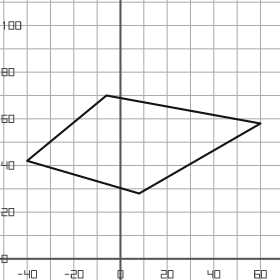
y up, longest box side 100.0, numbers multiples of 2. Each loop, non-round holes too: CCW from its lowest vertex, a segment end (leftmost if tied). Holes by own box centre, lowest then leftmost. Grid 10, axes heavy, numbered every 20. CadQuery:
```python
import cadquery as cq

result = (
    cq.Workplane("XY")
    .moveTo(8.0, 28.0)
    .lineTo(60.0, 58.0)
    .lineTo(-6.0, 70.0)
    .lineTo(-40.0, 42.0)
    .close()
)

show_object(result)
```